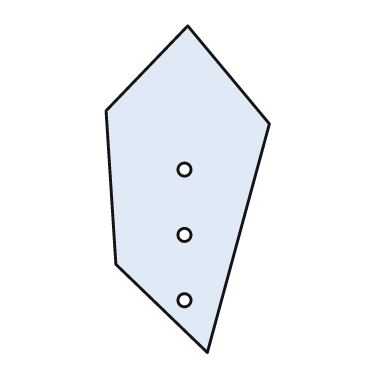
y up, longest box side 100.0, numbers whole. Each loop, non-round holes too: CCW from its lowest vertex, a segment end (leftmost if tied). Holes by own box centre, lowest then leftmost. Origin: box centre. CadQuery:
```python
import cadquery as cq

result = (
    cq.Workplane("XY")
    .moveTo(6.0, -50.0)
    .lineTo(25.0, 20.0)
    .lineTo(0.0, 50.0)
    .lineTo(-25.0, 24.0)
    .lineTo(-22.0, -23.0)
    .close()
    .moveTo(-1.0, -34.0)
    .circle(2.0)
    .moveTo(-1.0, -14.0)
    .circle(2.0)
    .moveTo(-1.0, 6.0)
    .circle(2.0)
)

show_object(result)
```